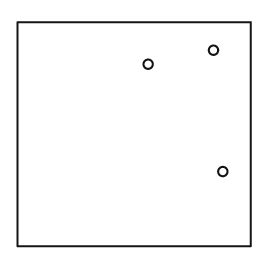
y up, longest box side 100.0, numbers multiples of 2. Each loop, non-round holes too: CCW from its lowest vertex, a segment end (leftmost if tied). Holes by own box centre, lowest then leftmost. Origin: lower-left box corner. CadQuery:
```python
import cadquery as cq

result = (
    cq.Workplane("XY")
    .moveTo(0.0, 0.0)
    .lineTo(100.0, 0.0)
    .lineTo(100.0, 96.0)
    .lineTo(0.0, 96.0)
    .close()
    .moveTo(88.0, 32.0)
    .circle(2.0)
    .moveTo(56.0, 78.0)
    .circle(2.0)
    .moveTo(84.0, 84.0)
    .circle(2.0)
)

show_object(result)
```